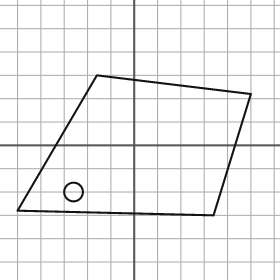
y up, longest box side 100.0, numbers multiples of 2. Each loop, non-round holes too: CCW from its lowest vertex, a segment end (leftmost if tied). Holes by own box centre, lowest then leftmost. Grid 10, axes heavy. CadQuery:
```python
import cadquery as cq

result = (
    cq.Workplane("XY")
    .moveTo(34.0, -30.0)
    .lineTo(50.0, 22.0)
    .lineTo(-16.0, 30.0)
    .lineTo(-50.0, -28.0)
    .close()
    .moveTo(-26.0, -20.0)
    .circle(4.0)
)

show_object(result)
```